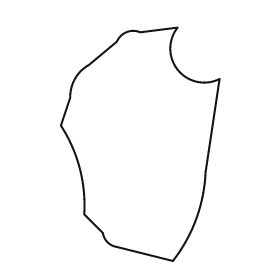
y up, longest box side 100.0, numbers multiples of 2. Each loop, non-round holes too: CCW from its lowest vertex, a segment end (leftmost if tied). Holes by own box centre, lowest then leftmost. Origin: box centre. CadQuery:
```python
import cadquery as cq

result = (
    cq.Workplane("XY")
    .moveTo(14.0, -50.0)
    .threePointArc((24.0, -32.0), (28.0, -12.0))
    .lineTo(34.0, 28.0)
    .threePointArc((16.0, 32.0), (16.0, 50.0))
    .lineTo(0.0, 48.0)
    .threePointArc((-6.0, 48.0), (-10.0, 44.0))
    .lineTo(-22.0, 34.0)
    .threePointArc((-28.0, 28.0), (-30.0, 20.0))
    .lineTo(-34.0, 8.0)
    .threePointArc((-26.0, -10.0), (-24.0, -30.0))
    .lineTo(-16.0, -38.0)
    .threePointArc((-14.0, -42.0), (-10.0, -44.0))
    .close()
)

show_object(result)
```